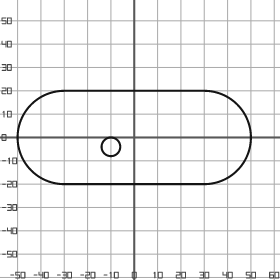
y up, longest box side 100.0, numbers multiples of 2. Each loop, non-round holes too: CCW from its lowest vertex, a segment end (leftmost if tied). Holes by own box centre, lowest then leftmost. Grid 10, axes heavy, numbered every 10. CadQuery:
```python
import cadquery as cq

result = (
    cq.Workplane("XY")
    .moveTo(-30.0, -20.0)
    .lineTo(30.0, -20.0)
    .threePointArc((50.0, 0.0), (30.0, 20.0))
    .lineTo(-30.0, 20.0)
    .threePointArc((-50.0, 0.0), (-30.0, -20.0))
    .close()
    .moveTo(-10.0, -4.0)
    .circle(4.0)
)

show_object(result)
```